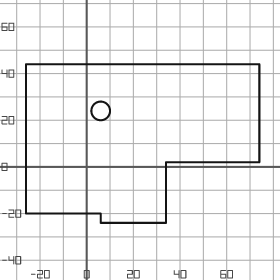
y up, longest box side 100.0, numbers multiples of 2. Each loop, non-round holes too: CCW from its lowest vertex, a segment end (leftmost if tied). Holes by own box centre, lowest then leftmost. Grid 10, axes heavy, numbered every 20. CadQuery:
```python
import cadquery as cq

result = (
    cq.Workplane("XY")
    .moveTo(6.0, -24.0)
    .lineTo(34.0, -24.0)
    .lineTo(34.0, 2.0)
    .lineTo(74.0, 2.0)
    .lineTo(74.0, 44.0)
    .lineTo(-26.0, 44.0)
    .lineTo(-26.0, -20.0)
    .lineTo(6.0, -20.0)
    .close()
    .moveTo(6.0, 24.0)
    .circle(4.0)
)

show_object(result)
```